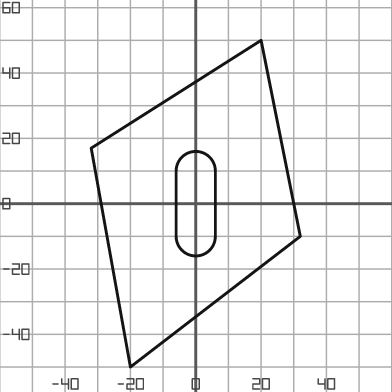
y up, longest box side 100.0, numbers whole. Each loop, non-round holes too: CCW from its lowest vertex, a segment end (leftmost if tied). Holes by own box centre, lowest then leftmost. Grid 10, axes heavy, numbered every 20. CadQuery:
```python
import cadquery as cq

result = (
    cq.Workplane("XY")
    .moveTo(-20.0, -50.0)
    .lineTo(32.0, -10.0)
    .lineTo(20.0, 50.0)
    .lineTo(-32.0, 17.0)
    .close()
    .moveTo(-6.0, -10.0)
    .threePointArc((0.0, -16.0), (6.0, -10.0))
    .lineTo(6.0, 10.0)
    .threePointArc((0.0, 16.0), (-6.0, 10.0))
    .close()
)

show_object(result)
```